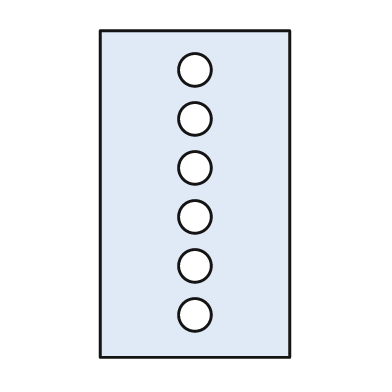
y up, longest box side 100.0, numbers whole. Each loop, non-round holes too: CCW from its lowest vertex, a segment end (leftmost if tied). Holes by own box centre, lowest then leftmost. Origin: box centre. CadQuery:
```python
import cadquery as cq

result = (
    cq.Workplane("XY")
    .moveTo(-29.0, -50.0)
    .lineTo(29.0, -50.0)
    .lineTo(29.0, 50.0)
    .lineTo(-29.0, 50.0)
    .close()
    .moveTo(0.0, -37.0)
    .circle(5.0)
    .moveTo(0.0, -22.0)
    .circle(5.0)
    .moveTo(0.0, -7.0)
    .circle(5.0)
    .moveTo(0.0, 8.0)
    .circle(5.0)
    .moveTo(0.0, 23.0)
    .circle(5.0)
    .moveTo(0.0, 38.0)
    .circle(5.0)
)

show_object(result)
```